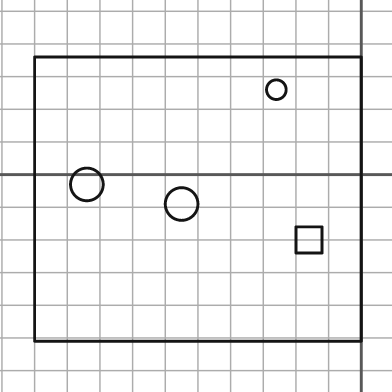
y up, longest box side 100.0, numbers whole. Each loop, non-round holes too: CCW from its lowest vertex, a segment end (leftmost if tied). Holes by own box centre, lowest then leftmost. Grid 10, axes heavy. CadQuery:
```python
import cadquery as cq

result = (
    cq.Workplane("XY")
    .moveTo(-100.0, -51.0)
    .lineTo(0.0, -51.0)
    .lineTo(0.0, 36.0)
    .lineTo(-100.0, 36.0)
    .close()
    .moveTo(-20.0, -24.0)
    .lineTo(-12.0, -24.0)
    .lineTo(-12.0, -16.0)
    .lineTo(-20.0, -16.0)
    .close()
    .moveTo(-55.0, -9.0)
    .circle(5.0)
    .moveTo(-84.0, -3.0)
    .circle(5.0)
    .moveTo(-26.0, 26.0)
    .circle(3.0)
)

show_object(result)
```